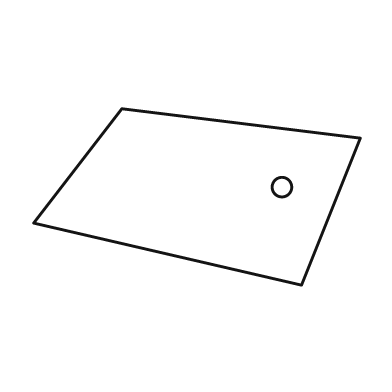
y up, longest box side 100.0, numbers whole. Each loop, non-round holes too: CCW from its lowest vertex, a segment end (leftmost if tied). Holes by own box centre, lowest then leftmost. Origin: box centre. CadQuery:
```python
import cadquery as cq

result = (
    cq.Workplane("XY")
    .moveTo(32.0, -27.0)
    .lineTo(50.0, 18.0)
    .lineTo(-23.0, 27.0)
    .lineTo(-50.0, -8.0)
    .close()
    .moveTo(26.0, 3.0)
    .circle(3.0)
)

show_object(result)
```